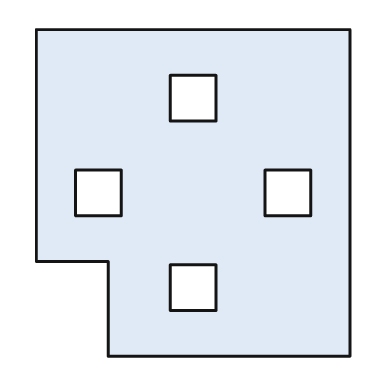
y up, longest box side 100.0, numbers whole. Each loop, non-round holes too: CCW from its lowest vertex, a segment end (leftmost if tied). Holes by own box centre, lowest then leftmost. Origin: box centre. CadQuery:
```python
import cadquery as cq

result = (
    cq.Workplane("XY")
    .moveTo(-26.0, -50.0)
    .lineTo(48.0, -50.0)
    .lineTo(48.0, 50.0)
    .lineTo(-48.0, 50.0)
    .lineTo(-48.0, -21.0)
    .lineTo(-26.0, -21.0)
    .close()
    .moveTo(-7.0, -36.0)
    .lineTo(7.0, -36.0)
    .lineTo(7.0, -22.0)
    .lineTo(-7.0, -22.0)
    .close()
    .moveTo(-36.0, -7.0)
    .lineTo(-22.0, -7.0)
    .lineTo(-22.0, 7.0)
    .lineTo(-36.0, 7.0)
    .close()
    .moveTo(22.0, -7.0)
    .lineTo(36.0, -7.0)
    .lineTo(36.0, 7.0)
    .lineTo(22.0, 7.0)
    .close()
    .moveTo(-7.0, 22.0)
    .lineTo(7.0, 22.0)
    .lineTo(7.0, 36.0)
    .lineTo(-7.0, 36.0)
    .close()
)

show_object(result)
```